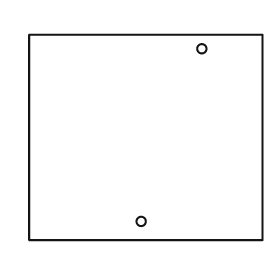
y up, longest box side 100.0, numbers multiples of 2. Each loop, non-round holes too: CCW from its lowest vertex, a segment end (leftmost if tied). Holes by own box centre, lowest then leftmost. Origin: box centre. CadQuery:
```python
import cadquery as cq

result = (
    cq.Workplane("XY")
    .moveTo(-50.0, -44.0)
    .lineTo(50.0, -44.0)
    .lineTo(50.0, 44.0)
    .lineTo(-50.0, 44.0)
    .close()
    .moveTo(-2.0, -36.0)
    .circle(2.0)
    .moveTo(24.0, 38.0)
    .circle(2.0)
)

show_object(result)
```